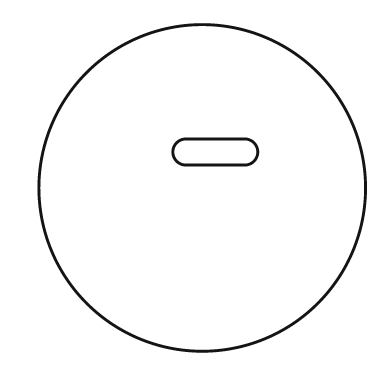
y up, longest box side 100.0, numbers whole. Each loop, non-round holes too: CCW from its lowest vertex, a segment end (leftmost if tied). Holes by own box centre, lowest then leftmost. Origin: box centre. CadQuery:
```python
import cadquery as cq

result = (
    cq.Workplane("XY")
    .moveTo(0.0, 0.0)
    .circle(50.0)
    .moveTo(-5.0, 7.0)
    .lineTo(13.0, 7.0)
    .threePointArc((17.0, 11.0), (13.0, 15.0))
    .lineTo(-5.0, 15.0)
    .threePointArc((-9.0, 11.0), (-5.0, 7.0))
    .close()
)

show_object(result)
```